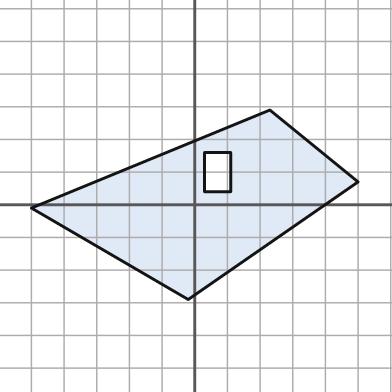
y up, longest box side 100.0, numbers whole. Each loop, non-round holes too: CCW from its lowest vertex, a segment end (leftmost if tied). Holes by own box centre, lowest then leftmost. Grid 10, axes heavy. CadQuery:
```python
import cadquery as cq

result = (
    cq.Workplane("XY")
    .moveTo(-2.0, -29.0)
    .lineTo(50.0, 7.0)
    .lineTo(23.0, 29.0)
    .lineTo(-50.0, -1.0)
    .close()
    .moveTo(3.0, 4.0)
    .lineTo(11.0, 4.0)
    .lineTo(11.0, 16.0)
    .lineTo(3.0, 16.0)
    .close()
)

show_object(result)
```